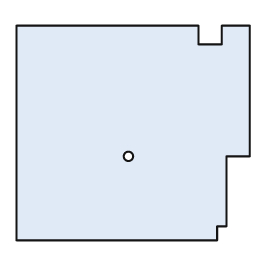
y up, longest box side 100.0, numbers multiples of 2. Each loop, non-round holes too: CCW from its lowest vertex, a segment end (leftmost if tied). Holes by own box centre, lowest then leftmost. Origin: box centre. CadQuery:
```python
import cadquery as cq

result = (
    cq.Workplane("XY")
    .moveTo(-50.0, -46.0)
    .lineTo(36.0, -46.0)
    .lineTo(36.0, -40.0)
    .lineTo(40.0, -40.0)
    .lineTo(40.0, -10.0)
    .lineTo(50.0, -10.0)
    .lineTo(50.0, 46.0)
    .lineTo(38.0, 46.0)
    .lineTo(38.0, 38.0)
    .lineTo(28.0, 38.0)
    .lineTo(28.0, 46.0)
    .lineTo(-50.0, 46.0)
    .close()
    .moveTo(-2.0, -10.0)
    .circle(2.0)
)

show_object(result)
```